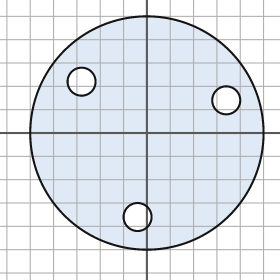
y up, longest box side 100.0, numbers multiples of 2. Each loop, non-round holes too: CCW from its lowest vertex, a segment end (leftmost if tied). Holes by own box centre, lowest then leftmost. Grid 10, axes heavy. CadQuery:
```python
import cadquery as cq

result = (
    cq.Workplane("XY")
    .moveTo(0.0, 0.0)
    .circle(50.0)
    .moveTo(-4.0, -36.0)
    .circle(6.0)
    .moveTo(34.0, 14.0)
    .circle(6.0)
    .moveTo(-28.0, 22.0)
    .circle(6.0)
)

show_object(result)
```